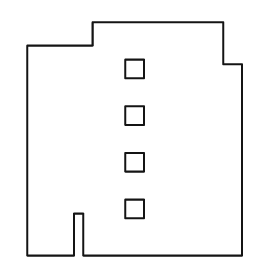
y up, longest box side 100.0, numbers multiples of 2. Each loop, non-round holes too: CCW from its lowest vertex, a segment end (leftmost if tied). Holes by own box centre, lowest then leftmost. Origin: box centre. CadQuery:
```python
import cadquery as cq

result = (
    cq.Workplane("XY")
    .moveTo(-46.0, -50.0)
    .lineTo(-26.0, -50.0)
    .lineTo(-26.0, -32.0)
    .lineTo(-22.0, -32.0)
    .lineTo(-22.0, -50.0)
    .lineTo(46.0, -50.0)
    .lineTo(46.0, 32.0)
    .lineTo(38.0, 32.0)
    .lineTo(38.0, 50.0)
    .lineTo(-18.0, 50.0)
    .lineTo(-18.0, 40.0)
    .lineTo(-46.0, 40.0)
    .close()
    .moveTo(-4.0, -34.0)
    .lineTo(4.0, -34.0)
    .lineTo(4.0, -26.0)
    .lineTo(-4.0, -26.0)
    .close()
    .moveTo(-4.0, -14.0)
    .lineTo(4.0, -14.0)
    .lineTo(4.0, -6.0)
    .lineTo(-4.0, -6.0)
    .close()
    .moveTo(-4.0, 6.0)
    .lineTo(4.0, 6.0)
    .lineTo(4.0, 14.0)
    .lineTo(-4.0, 14.0)
    .close()
    .moveTo(-4.0, 26.0)
    .lineTo(4.0, 26.0)
    .lineTo(4.0, 34.0)
    .lineTo(-4.0, 34.0)
    .close()
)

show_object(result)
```